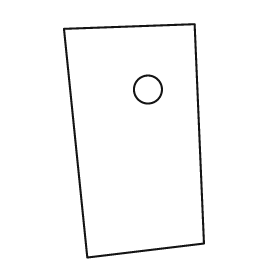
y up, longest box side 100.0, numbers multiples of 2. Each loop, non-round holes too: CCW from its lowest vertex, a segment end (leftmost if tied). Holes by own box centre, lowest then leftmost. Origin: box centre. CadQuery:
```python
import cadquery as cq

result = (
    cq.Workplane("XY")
    .moveTo(-20.0, -50.0)
    .lineTo(30.0, -44.0)
    .lineTo(26.0, 50.0)
    .lineTo(-30.0, 48.0)
    .close()
    .moveTo(6.0, 22.0)
    .circle(6.0)
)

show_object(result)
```